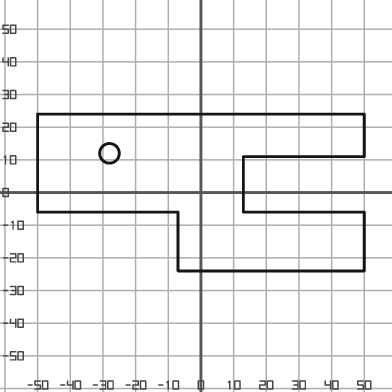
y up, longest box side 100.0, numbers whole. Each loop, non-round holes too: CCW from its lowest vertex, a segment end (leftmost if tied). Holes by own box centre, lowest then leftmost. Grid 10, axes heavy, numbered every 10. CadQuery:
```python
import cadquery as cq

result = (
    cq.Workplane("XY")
    .moveTo(-7.0, -24.0)
    .lineTo(50.0, -24.0)
    .lineTo(50.0, -6.0)
    .lineTo(13.0, -6.0)
    .lineTo(13.0, 11.0)
    .lineTo(50.0, 11.0)
    .lineTo(50.0, 24.0)
    .lineTo(-50.0, 24.0)
    .lineTo(-50.0, -6.0)
    .lineTo(-7.0, -6.0)
    .close()
    .moveTo(-28.0, 12.0)
    .circle(3.0)
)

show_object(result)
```